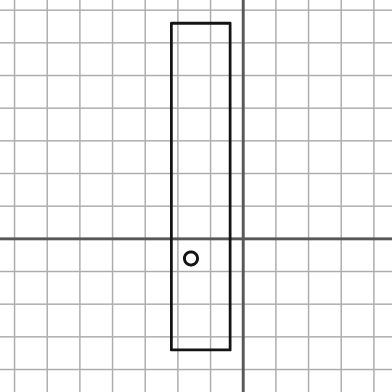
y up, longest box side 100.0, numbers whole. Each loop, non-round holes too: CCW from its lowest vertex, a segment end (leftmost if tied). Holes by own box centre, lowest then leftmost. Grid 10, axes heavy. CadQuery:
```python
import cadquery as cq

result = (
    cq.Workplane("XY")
    .moveTo(-22.0, -34.0)
    .lineTo(-4.0, -34.0)
    .lineTo(-4.0, 66.0)
    .lineTo(-22.0, 66.0)
    .close()
    .moveTo(-16.0, -6.0)
    .circle(2.0)
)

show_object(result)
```